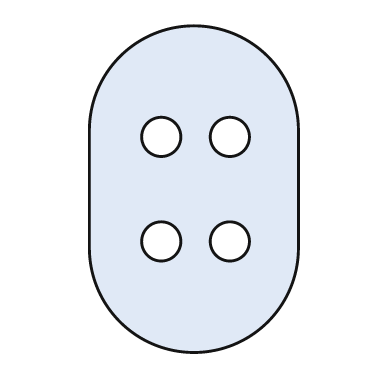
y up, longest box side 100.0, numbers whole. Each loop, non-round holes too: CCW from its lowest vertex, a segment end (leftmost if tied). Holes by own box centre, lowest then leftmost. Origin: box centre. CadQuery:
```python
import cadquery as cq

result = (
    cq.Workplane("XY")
    .moveTo(-32.0, -18.0)
    .threePointArc((0.0, -50.0), (32.0, -18.0))
    .lineTo(32.0, 18.0)
    .threePointArc((0.0, 50.0), (-32.0, 18.0))
    .close()
    .moveTo(-10.0, -16.0)
    .circle(6.0)
    .moveTo(11.0, -16.0)
    .circle(6.0)
    .moveTo(-10.0, 16.0)
    .circle(6.0)
    .moveTo(11.0, 16.0)
    .circle(6.0)
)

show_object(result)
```